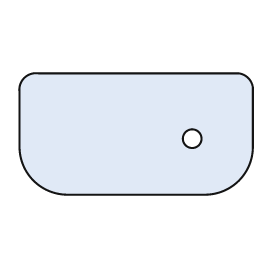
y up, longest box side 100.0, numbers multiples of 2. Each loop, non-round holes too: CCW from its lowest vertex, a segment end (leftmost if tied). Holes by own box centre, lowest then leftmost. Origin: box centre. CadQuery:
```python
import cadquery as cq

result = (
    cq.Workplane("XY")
    .moveTo(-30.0, -26.0)
    .lineTo(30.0, -26.0)
    .threePointArc((44.0, -20.0), (50.0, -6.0))
    .lineTo(50.0, 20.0)
    .threePointArc((48.0, 24.0), (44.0, 26.0))
    .lineTo(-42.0, 26.0)
    .threePointArc((-48.0, 24.0), (-50.0, 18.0))
    .lineTo(-50.0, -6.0)
    .threePointArc((-44.0, -20.0), (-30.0, -26.0))
    .close()
    .moveTo(24.0, -2.0)
    .circle(4.0)
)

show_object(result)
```